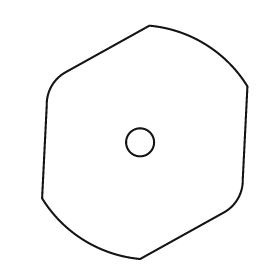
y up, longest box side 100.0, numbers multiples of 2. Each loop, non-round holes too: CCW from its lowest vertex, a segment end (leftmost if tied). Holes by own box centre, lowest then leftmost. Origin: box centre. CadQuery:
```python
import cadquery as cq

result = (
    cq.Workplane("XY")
    .moveTo(-2.0, -50.0)
    .lineTo(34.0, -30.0)
    .threePointArc((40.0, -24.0), (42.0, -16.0))
    .lineTo(44.0, 24.0)
    .threePointArc((26.0, 42.0), (2.0, 50.0))
    .lineTo(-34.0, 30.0)
    .threePointArc((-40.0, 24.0), (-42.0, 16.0))
    .lineTo(-44.0, -24.0)
    .threePointArc((-26.0, -42.0), (-2.0, -50.0))
    .close()
    .moveTo(-2.0, 0.0)
    .circle(6.0)
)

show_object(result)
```